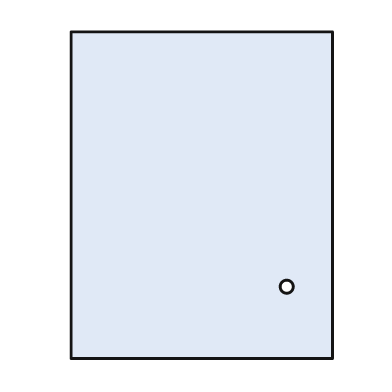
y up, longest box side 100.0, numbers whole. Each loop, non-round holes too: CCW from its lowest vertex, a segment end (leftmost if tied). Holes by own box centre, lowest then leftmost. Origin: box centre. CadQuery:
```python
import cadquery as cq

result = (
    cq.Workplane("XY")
    .moveTo(-40.0, -50.0)
    .lineTo(40.0, -50.0)
    .lineTo(40.0, 50.0)
    .lineTo(-40.0, 50.0)
    .close()
    .moveTo(26.0, -28.0)
    .circle(2.0)
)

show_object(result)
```